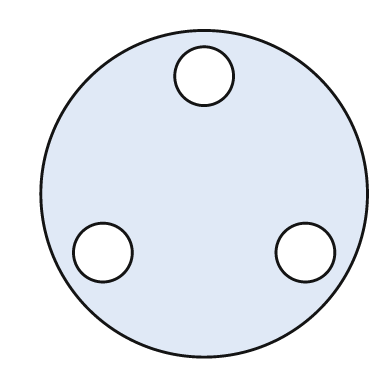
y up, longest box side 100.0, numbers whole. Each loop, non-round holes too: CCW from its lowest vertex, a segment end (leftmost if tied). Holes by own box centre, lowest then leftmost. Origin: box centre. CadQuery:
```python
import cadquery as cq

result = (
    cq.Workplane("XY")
    .moveTo(0.0, 0.0)
    .circle(50.0)
    .moveTo(-31.0, -18.0)
    .circle(9.0)
    .moveTo(31.0, -18.0)
    .circle(9.0)
    .moveTo(0.0, 36.0)
    .circle(9.0)
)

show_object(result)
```